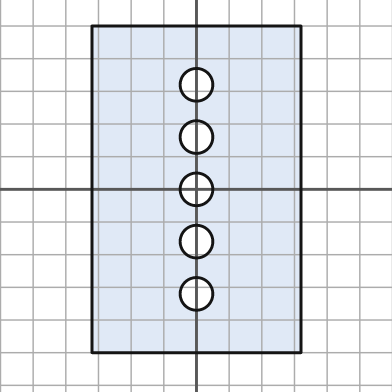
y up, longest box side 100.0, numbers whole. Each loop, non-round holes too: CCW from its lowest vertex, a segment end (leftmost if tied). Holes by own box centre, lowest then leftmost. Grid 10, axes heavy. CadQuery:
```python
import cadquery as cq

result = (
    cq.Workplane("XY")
    .moveTo(-32.0, -50.0)
    .lineTo(32.0, -50.0)
    .lineTo(32.0, 50.0)
    .lineTo(-32.0, 50.0)
    .close()
    .moveTo(0.0, -32.0)
    .circle(5.0)
    .moveTo(0.0, -16.0)
    .circle(5.0)
    .moveTo(0.0, 0.0)
    .circle(5.0)
    .moveTo(0.0, 16.0)
    .circle(5.0)
    .moveTo(0.0, 32.0)
    .circle(5.0)
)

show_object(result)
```